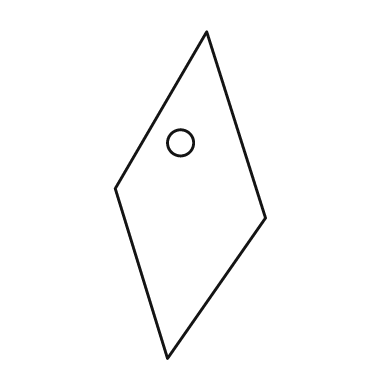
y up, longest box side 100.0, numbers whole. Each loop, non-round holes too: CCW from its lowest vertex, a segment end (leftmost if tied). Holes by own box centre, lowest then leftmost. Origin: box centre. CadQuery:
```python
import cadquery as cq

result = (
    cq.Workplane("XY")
    .moveTo(-7.0, -50.0)
    .lineTo(23.0, -7.0)
    .lineTo(5.0, 50.0)
    .lineTo(-23.0, 2.0)
    .close()
    .moveTo(-3.0, 16.0)
    .circle(4.0)
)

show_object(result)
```